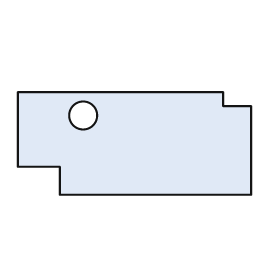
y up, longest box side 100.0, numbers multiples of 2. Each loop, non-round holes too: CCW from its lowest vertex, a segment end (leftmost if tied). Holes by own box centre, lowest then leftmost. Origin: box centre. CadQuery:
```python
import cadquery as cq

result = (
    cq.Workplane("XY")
    .moveTo(-32.0, -22.0)
    .lineTo(50.0, -22.0)
    .lineTo(50.0, 16.0)
    .lineTo(38.0, 16.0)
    .lineTo(38.0, 22.0)
    .lineTo(-50.0, 22.0)
    .lineTo(-50.0, -10.0)
    .lineTo(-32.0, -10.0)
    .close()
    .moveTo(-22.0, 12.0)
    .circle(6.0)
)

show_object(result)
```